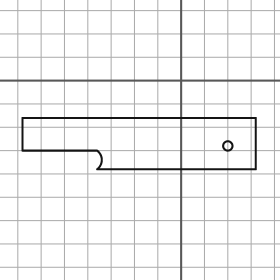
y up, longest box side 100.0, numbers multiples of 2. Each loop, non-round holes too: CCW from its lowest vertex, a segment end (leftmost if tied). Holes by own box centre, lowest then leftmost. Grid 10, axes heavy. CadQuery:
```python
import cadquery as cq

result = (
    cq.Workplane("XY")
    .moveTo(-36.0, -38.0)
    .lineTo(32.0, -38.0)
    .lineTo(32.0, -16.0)
    .lineTo(-68.0, -16.0)
    .lineTo(-68.0, -30.0)
    .lineTo(-36.0, -30.0)
    .threePointArc((-34.0, -34.0), (-36.0, -38.0))
    .close()
    .moveTo(20.0, -28.0)
    .circle(2.0)
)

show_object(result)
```